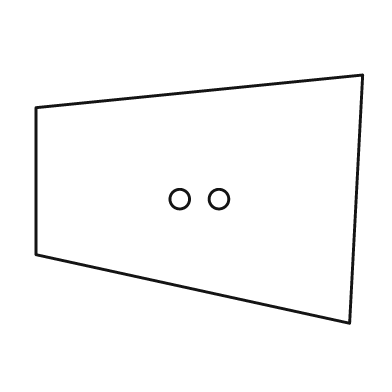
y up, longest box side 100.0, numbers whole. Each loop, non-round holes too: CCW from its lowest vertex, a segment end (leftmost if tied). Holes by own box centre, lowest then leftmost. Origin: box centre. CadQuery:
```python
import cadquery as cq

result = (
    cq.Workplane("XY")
    .moveTo(46.0, -38.0)
    .lineTo(50.0, 38.0)
    .lineTo(-50.0, 28.0)
    .lineTo(-50.0, -17.0)
    .close()
    .moveTo(-6.0, 0.0)
    .circle(3.0)
    .moveTo(6.0, 0.0)
    .circle(3.0)
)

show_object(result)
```